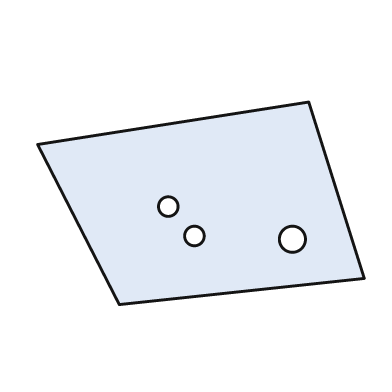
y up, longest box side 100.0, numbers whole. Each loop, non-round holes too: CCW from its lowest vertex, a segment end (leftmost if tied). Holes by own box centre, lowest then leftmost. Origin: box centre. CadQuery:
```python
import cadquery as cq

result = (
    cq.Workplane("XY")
    .moveTo(-25.0, -31.0)
    .lineTo(50.0, -23.0)
    .lineTo(33.0, 31.0)
    .lineTo(-50.0, 18.0)
    .close()
    .moveTo(28.0, -11.0)
    .circle(4.0)
    .moveTo(-2.0, -10.0)
    .circle(3.0)
    .moveTo(-10.0, -1.0)
    .circle(3.0)
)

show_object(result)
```